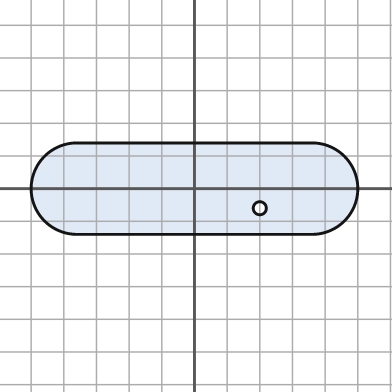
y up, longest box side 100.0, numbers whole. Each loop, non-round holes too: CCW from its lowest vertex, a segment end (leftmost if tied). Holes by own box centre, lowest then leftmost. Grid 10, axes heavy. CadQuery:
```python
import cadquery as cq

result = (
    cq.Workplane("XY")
    .moveTo(-36.0, -14.0)
    .lineTo(36.0, -14.0)
    .threePointArc((50.0, 0.0), (36.0, 14.0))
    .lineTo(-36.0, 14.0)
    .threePointArc((-50.0, 0.0), (-36.0, -14.0))
    .close()
    .moveTo(20.0, -6.0)
    .circle(2.0)
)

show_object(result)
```